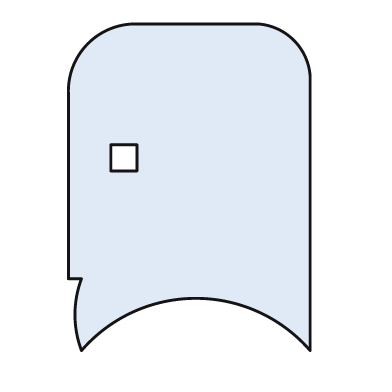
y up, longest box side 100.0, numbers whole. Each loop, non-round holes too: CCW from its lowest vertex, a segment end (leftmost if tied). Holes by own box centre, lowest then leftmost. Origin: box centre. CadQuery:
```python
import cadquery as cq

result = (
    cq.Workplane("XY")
    .moveTo(-33.0, -50.0)
    .threePointArc((2.0, -34.0), (37.0, -50.0))
    .lineTo(37.0, 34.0)
    .threePointArc((32.0, 45.0), (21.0, 50.0))
    .lineTo(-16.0, 50.0)
    .threePointArc((-31.0, 44.0), (-37.0, 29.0))
    .lineTo(-37.0, -28.0)
    .lineTo(-33.0, -28.0)
    .threePointArc((-35.0, -39.0), (-33.0, -50.0))
    .close()
    .moveTo(-24.0, 5.0)
    .lineTo(-16.0, 5.0)
    .lineTo(-16.0, 13.0)
    .lineTo(-24.0, 13.0)
    .close()
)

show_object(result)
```